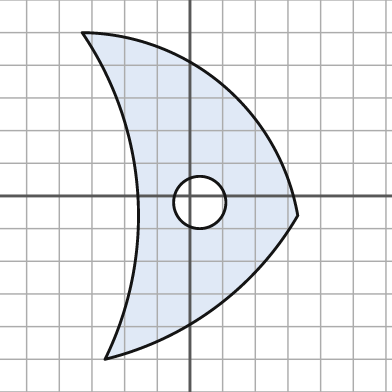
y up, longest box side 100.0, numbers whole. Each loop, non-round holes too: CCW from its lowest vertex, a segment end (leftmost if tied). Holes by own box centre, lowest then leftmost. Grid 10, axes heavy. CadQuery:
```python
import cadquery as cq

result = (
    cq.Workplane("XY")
    .moveTo(-26.0, -50.0)
    .threePointArc((8.0, -34.0), (33.0, -6.0))
    .threePointArc((10.0, 34.0), (-33.0, 50.0))
    .threePointArc((-16.0, 1.0), (-26.0, -50.0))
    .close()
    .moveTo(3.0, -2.0)
    .circle(8.0)
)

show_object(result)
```